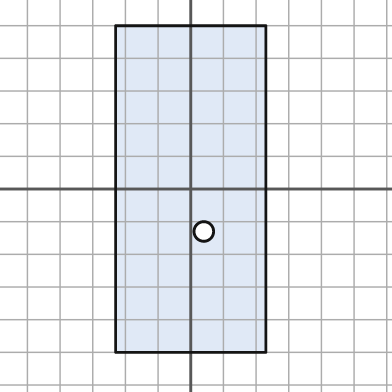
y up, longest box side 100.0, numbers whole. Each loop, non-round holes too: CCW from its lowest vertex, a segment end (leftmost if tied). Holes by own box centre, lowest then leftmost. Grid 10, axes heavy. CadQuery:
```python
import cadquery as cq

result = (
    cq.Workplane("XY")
    .moveTo(-23.0, -50.0)
    .lineTo(23.0, -50.0)
    .lineTo(23.0, 50.0)
    .lineTo(-23.0, 50.0)
    .close()
    .moveTo(4.0, -13.0)
    .circle(3.0)
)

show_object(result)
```